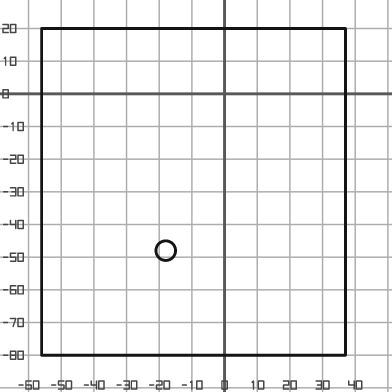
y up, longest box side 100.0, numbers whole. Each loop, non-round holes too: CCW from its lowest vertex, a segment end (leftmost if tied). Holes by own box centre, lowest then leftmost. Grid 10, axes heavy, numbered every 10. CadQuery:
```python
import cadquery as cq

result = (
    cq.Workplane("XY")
    .moveTo(-56.0, -80.0)
    .lineTo(37.0, -80.0)
    .lineTo(37.0, 20.0)
    .lineTo(-56.0, 20.0)
    .close()
    .moveTo(-18.0, -48.0)
    .circle(3.0)
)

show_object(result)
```